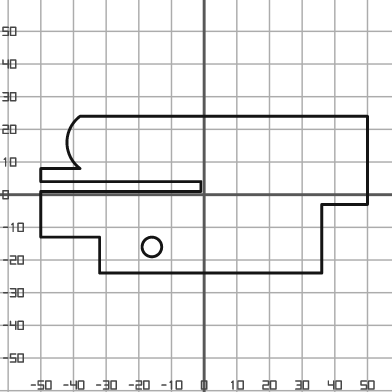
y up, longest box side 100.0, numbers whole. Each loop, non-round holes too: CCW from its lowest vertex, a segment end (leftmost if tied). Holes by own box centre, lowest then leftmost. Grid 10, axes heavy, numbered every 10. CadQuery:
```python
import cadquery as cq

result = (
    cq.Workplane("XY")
    .moveTo(-32.0, -24.0)
    .lineTo(36.0, -24.0)
    .lineTo(36.0, -3.0)
    .lineTo(50.0, -3.0)
    .lineTo(50.0, 24.0)
    .lineTo(-38.0, 24.0)
    .threePointArc((-42.0, 16.0), (-38.0, 8.0))
    .lineTo(-50.0, 8.0)
    .lineTo(-50.0, 4.0)
    .lineTo(-1.0, 4.0)
    .lineTo(-1.0, 1.0)
    .lineTo(-50.0, 1.0)
    .lineTo(-50.0, -13.0)
    .lineTo(-32.0, -13.0)
    .close()
    .moveTo(-16.0, -16.0)
    .circle(3.0)
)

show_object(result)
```